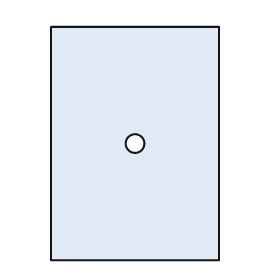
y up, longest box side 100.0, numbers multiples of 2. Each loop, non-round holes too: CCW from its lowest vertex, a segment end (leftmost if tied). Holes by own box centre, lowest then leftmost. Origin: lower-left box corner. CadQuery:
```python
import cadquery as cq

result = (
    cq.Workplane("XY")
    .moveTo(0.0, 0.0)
    .lineTo(72.0, 0.0)
    .lineTo(72.0, 100.0)
    .lineTo(0.0, 100.0)
    .close()
    .moveTo(36.0, 50.0)
    .circle(4.0)
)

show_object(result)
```